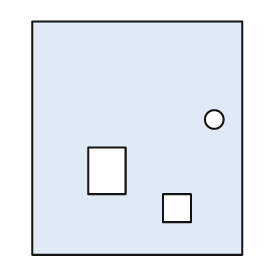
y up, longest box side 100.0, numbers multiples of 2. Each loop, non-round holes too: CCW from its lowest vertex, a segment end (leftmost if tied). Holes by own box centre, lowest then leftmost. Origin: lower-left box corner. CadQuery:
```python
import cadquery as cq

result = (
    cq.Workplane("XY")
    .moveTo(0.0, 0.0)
    .lineTo(90.0, 0.0)
    .lineTo(90.0, 100.0)
    .lineTo(0.0, 100.0)
    .close()
    .moveTo(56.0, 14.0)
    .lineTo(68.0, 14.0)
    .lineTo(68.0, 26.0)
    .lineTo(56.0, 26.0)
    .close()
    .moveTo(24.0, 26.0)
    .lineTo(40.0, 26.0)
    .lineTo(40.0, 46.0)
    .lineTo(24.0, 46.0)
    .close()
    .moveTo(78.0, 58.0)
    .circle(4.0)
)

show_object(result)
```